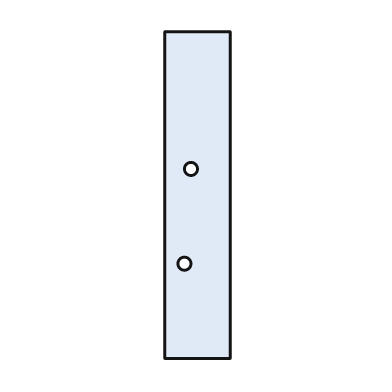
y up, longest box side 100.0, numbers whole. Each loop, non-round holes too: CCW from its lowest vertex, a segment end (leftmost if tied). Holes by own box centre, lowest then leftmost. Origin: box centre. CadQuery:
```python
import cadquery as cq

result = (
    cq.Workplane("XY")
    .moveTo(-10.0, -50.0)
    .lineTo(10.0, -50.0)
    .lineTo(10.0, 50.0)
    .lineTo(-10.0, 50.0)
    .close()
    .moveTo(-4.0, -21.0)
    .circle(2.0)
    .moveTo(-2.0, 8.0)
    .circle(2.0)
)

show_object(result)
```